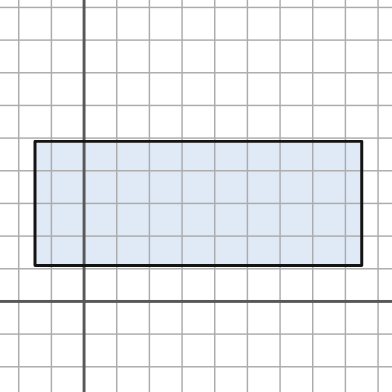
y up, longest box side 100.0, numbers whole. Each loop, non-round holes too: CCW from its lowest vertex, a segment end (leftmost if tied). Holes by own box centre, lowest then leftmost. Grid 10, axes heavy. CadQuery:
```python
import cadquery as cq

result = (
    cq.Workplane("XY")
    .moveTo(-15.0, 11.0)
    .lineTo(85.0, 11.0)
    .lineTo(85.0, 49.0)
    .lineTo(-15.0, 49.0)
    .close()
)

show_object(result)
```